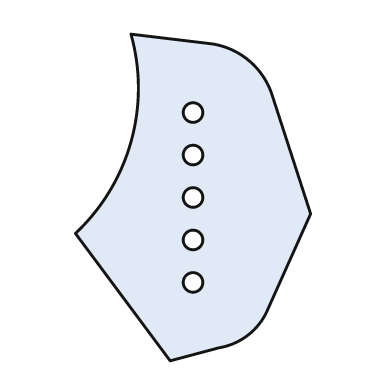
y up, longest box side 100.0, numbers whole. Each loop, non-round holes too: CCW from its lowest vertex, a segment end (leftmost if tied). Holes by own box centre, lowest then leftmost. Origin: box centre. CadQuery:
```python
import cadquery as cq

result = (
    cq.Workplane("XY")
    .moveTo(-7.0, -50.0)
    .lineTo(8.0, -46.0)
    .threePointArc((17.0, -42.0), (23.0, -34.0))
    .lineTo(36.0, -5.0)
    .lineTo(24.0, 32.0)
    .threePointArc((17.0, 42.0), (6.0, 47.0))
    .lineTo(-19.0, 50.0)
    .threePointArc((-19.0, 17.0), (-36.0, -11.0))
    .close()
    .moveTo(0.0, -26.0)
    .circle(3.0)
    .moveTo(0.0, -13.0)
    .circle(3.0)
    .moveTo(0.0, 0.0)
    .circle(3.0)
    .moveTo(0.0, 13.0)
    .circle(3.0)
    .moveTo(0.0, 26.0)
    .circle(3.0)
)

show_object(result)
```